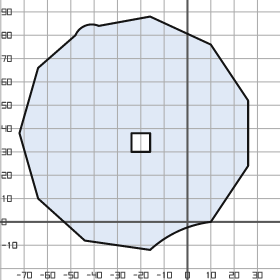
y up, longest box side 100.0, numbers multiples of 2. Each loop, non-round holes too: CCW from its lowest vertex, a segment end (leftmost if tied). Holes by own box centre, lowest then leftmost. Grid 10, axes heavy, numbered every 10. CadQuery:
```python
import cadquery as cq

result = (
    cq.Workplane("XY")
    .moveTo(-16.0, -12.0)
    .threePointArc((-4.0, -4.0), (10.0, 0.0))
    .lineTo(26.0, 24.0)
    .lineTo(26.0, 52.0)
    .lineTo(10.0, 76.0)
    .lineTo(-16.0, 88.0)
    .lineTo(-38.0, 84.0)
    .threePointArc((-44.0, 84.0), (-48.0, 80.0))
    .lineTo(-64.0, 66.0)
    .lineTo(-72.0, 38.0)
    .lineTo(-64.0, 10.0)
    .lineTo(-44.0, -8.0)
    .close()
    .moveTo(-24.0, 30.0)
    .lineTo(-16.0, 30.0)
    .lineTo(-16.0, 38.0)
    .lineTo(-24.0, 38.0)
    .close()
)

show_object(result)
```